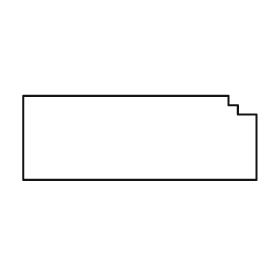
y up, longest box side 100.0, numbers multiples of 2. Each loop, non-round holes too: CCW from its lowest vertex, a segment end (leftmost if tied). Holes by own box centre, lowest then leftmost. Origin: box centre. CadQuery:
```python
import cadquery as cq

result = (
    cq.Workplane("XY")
    .moveTo(-50.0, -18.0)
    .lineTo(50.0, -18.0)
    .lineTo(50.0, 10.0)
    .lineTo(42.0, 10.0)
    .lineTo(42.0, 14.0)
    .lineTo(38.0, 14.0)
    .lineTo(38.0, 18.0)
    .lineTo(-50.0, 18.0)
    .close()
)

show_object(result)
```